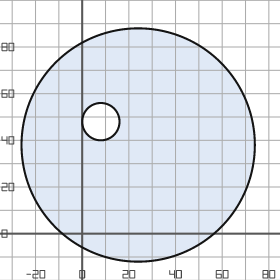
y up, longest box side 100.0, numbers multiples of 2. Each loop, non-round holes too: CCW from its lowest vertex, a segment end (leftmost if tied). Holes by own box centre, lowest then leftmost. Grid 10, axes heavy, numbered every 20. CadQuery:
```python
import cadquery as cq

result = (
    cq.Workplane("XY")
    .moveTo(24.0, 38.0)
    .circle(50.0)
    .moveTo(8.0, 48.0)
    .circle(8.0)
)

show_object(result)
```